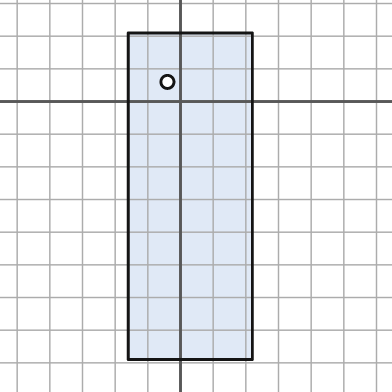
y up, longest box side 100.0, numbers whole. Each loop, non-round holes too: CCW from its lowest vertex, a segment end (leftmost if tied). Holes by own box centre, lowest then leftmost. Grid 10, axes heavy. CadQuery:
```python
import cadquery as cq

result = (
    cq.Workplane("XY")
    .moveTo(-16.0, -79.0)
    .lineTo(22.0, -79.0)
    .lineTo(22.0, 21.0)
    .lineTo(-16.0, 21.0)
    .close()
    .moveTo(-4.0, 6.0)
    .circle(2.0)
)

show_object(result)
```